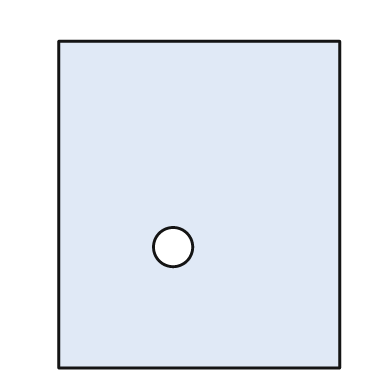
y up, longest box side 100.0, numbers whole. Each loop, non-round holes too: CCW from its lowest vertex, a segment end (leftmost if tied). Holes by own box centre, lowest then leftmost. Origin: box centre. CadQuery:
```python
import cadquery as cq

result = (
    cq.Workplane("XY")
    .moveTo(-43.0, -50.0)
    .lineTo(43.0, -50.0)
    .lineTo(43.0, 50.0)
    .lineTo(-43.0, 50.0)
    .close()
    .moveTo(-8.0, -13.0)
    .circle(6.0)
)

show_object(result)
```